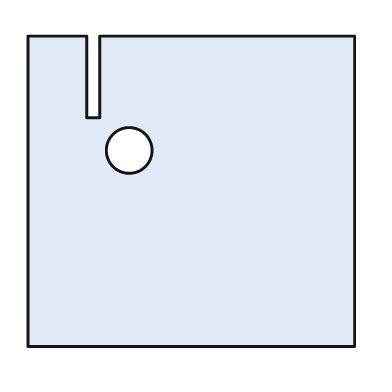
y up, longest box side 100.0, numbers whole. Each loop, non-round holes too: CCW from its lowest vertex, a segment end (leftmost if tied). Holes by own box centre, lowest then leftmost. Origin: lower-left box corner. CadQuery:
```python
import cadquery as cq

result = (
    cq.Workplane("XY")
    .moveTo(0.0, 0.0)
    .lineTo(100.0, 0.0)
    .lineTo(100.0, 95.0)
    .lineTo(22.0, 95.0)
    .lineTo(22.0, 70.0)
    .lineTo(18.0, 70.0)
    .lineTo(18.0, 95.0)
    .lineTo(0.0, 95.0)
    .close()
    .moveTo(31.0, 60.0)
    .circle(7.0)
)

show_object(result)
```